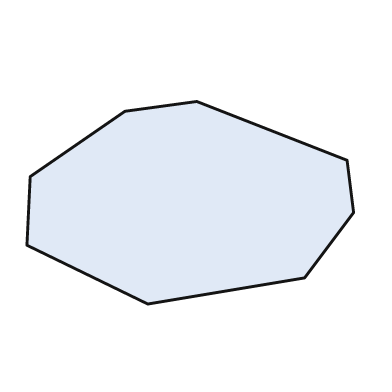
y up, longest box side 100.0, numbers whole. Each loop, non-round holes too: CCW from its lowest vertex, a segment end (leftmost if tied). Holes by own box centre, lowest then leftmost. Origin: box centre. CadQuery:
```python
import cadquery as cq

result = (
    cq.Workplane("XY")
    .moveTo(-13.0, -31.0)
    .lineTo(35.0, -23.0)
    .lineTo(50.0, -3.0)
    .lineTo(48.0, 13.0)
    .lineTo(2.0, 31.0)
    .lineTo(-20.0, 28.0)
    .lineTo(-49.0, 8.0)
    .lineTo(-50.0, -13.0)
    .close()
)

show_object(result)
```